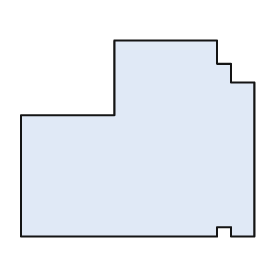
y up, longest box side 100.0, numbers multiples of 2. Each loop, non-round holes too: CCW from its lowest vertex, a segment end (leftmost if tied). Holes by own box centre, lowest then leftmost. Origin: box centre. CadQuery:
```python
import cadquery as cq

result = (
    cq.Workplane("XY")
    .moveTo(-50.0, -42.0)
    .lineTo(34.0, -42.0)
    .lineTo(34.0, -38.0)
    .lineTo(40.0, -38.0)
    .lineTo(40.0, -42.0)
    .lineTo(50.0, -42.0)
    .lineTo(50.0, 24.0)
    .lineTo(40.0, 24.0)
    .lineTo(40.0, 32.0)
    .lineTo(34.0, 32.0)
    .lineTo(34.0, 42.0)
    .lineTo(-10.0, 42.0)
    .lineTo(-10.0, 10.0)
    .lineTo(-50.0, 10.0)
    .close()
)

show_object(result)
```